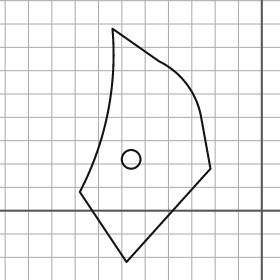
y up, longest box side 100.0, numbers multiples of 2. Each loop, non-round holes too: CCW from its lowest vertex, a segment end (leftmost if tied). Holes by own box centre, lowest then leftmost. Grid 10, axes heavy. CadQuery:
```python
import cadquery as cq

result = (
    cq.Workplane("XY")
    .moveTo(-58.0, -22.0)
    .lineTo(-22.0, 18.0)
    .lineTo(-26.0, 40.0)
    .threePointArc((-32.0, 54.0), (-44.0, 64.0))
    .lineTo(-64.0, 78.0)
    .threePointArc((-66.0, 42.0), (-78.0, 8.0))
    .close()
    .moveTo(-56.0, 22.0)
    .circle(4.0)
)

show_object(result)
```